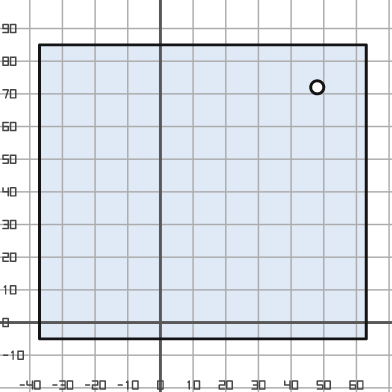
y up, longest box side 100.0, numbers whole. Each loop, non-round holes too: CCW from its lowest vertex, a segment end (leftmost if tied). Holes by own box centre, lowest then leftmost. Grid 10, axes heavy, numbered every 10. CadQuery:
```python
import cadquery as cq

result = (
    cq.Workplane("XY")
    .moveTo(-37.0, -5.0)
    .lineTo(63.0, -5.0)
    .lineTo(63.0, 85.0)
    .lineTo(-37.0, 85.0)
    .close()
    .moveTo(48.0, 72.0)
    .circle(2.0)
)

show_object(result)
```